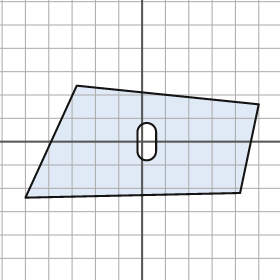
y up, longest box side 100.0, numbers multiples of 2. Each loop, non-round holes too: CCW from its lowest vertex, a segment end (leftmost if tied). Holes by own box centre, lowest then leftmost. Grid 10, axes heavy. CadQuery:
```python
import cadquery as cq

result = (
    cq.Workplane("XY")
    .moveTo(-50.0, -24.0)
    .lineTo(42.0, -22.0)
    .lineTo(50.0, 16.0)
    .lineTo(-28.0, 24.0)
    .close()
    .moveTo(-2.0, -4.0)
    .threePointArc((2.0, -8.0), (6.0, -4.0))
    .lineTo(6.0, 4.0)
    .threePointArc((2.0, 8.0), (-2.0, 4.0))
    .close()
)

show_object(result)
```